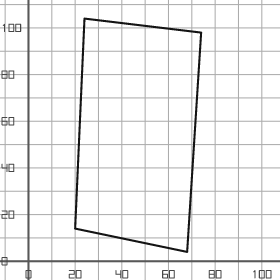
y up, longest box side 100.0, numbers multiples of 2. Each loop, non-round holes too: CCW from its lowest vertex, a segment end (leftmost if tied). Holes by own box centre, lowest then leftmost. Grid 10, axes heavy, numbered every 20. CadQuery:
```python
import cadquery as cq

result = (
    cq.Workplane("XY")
    .moveTo(68.0, 4.0)
    .lineTo(74.0, 98.0)
    .lineTo(24.0, 104.0)
    .lineTo(20.0, 14.0)
    .close()
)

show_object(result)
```